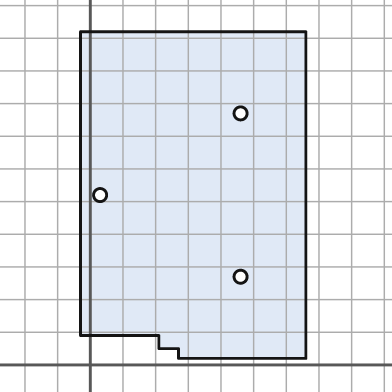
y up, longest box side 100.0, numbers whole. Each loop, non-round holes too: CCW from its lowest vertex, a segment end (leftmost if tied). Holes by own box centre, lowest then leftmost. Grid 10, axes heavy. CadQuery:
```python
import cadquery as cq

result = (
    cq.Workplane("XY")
    .moveTo(27.0, 2.0)
    .lineTo(66.0, 2.0)
    .lineTo(66.0, 102.0)
    .lineTo(-3.0, 102.0)
    .lineTo(-3.0, 9.0)
    .lineTo(21.0, 9.0)
    .lineTo(21.0, 5.0)
    .lineTo(27.0, 5.0)
    .close()
    .moveTo(46.0, 27.0)
    .circle(2.0)
    .moveTo(3.0, 52.0)
    .circle(2.0)
    .moveTo(46.0, 77.0)
    .circle(2.0)
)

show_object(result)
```